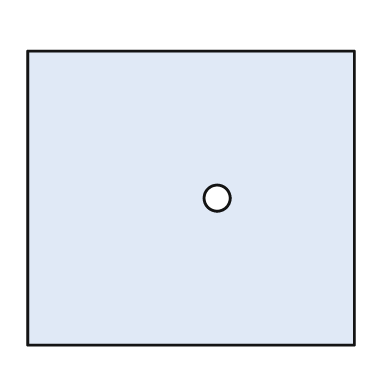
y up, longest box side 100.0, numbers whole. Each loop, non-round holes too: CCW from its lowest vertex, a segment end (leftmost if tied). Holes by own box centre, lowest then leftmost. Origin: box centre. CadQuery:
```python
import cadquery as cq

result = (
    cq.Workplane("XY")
    .moveTo(-50.0, -45.0)
    .lineTo(50.0, -45.0)
    .lineTo(50.0, 45.0)
    .lineTo(-50.0, 45.0)
    .close()
    .moveTo(8.0, 0.0)
    .circle(4.0)
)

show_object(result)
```